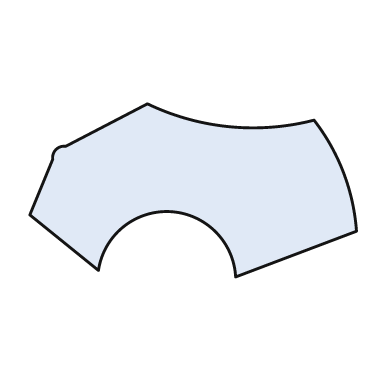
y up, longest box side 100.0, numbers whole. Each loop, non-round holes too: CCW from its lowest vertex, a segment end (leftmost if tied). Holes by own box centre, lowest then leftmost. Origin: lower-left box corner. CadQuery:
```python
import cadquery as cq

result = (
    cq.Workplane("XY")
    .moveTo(63.0, 0.0)
    .lineTo(100.0, 14.0)
    .threePointArc((96.0, 32.0), (87.0, 48.0))
    .threePointArc((61.0, 46.0), (36.0, 53.0))
    .lineTo(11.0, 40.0)
    .threePointArc((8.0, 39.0), (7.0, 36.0))
    .lineTo(0.0, 19.0)
    .lineTo(21.0, 2.0)
    .threePointArc((43.0, 20.0), (63.0, 0.0))
    .close()
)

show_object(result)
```